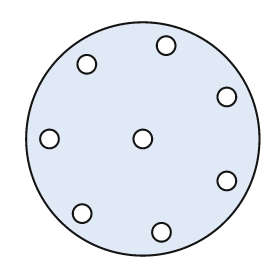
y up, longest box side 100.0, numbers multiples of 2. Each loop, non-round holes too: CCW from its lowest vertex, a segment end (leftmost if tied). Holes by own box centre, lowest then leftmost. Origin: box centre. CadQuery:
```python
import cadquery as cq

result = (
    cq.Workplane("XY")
    .moveTo(0.0, 0.0)
    .circle(50.0)
    .moveTo(8.0, -40.0)
    .circle(4.0)
    .moveTo(-26.0, -32.0)
    .circle(4.0)
    .moveTo(36.0, -18.0)
    .circle(4.0)
    .moveTo(-40.0, 0.0)
    .circle(4.0)
    .moveTo(0.0, 0.0)
    .circle(4.0)
    .moveTo(36.0, 18.0)
    .circle(4.0)
    .moveTo(-24.0, 32.0)
    .circle(4.0)
    .moveTo(10.0, 40.0)
    .circle(4.0)
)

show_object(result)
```